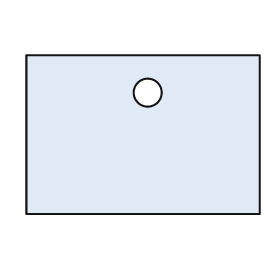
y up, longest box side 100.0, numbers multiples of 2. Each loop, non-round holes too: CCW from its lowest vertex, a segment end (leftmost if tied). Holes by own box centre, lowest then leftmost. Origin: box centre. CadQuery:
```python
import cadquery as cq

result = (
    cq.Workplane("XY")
    .moveTo(-50.0, -34.0)
    .lineTo(50.0, -34.0)
    .lineTo(50.0, 34.0)
    .lineTo(-50.0, 34.0)
    .close()
    .moveTo(2.0, 18.0)
    .circle(6.0)
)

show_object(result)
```